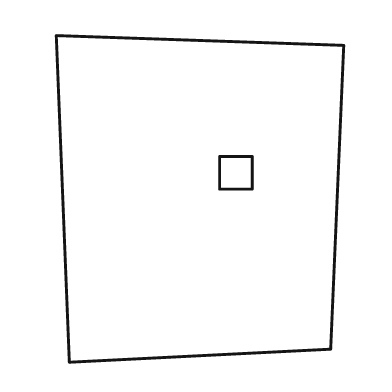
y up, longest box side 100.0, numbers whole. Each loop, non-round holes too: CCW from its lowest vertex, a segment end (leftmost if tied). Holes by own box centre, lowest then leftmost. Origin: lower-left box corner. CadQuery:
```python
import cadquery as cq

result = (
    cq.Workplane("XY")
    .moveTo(4.0, 0.0)
    .lineTo(84.0, 4.0)
    .lineTo(88.0, 97.0)
    .lineTo(0.0, 100.0)
    .close()
    .moveTo(50.0, 53.0)
    .lineTo(60.0, 53.0)
    .lineTo(60.0, 63.0)
    .lineTo(50.0, 63.0)
    .close()
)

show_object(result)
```